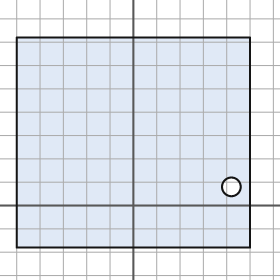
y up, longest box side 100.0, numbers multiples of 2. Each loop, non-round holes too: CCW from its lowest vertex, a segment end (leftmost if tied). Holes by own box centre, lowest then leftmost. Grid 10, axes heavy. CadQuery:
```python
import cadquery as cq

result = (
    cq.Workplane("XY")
    .moveTo(-50.0, -18.0)
    .lineTo(50.0, -18.0)
    .lineTo(50.0, 72.0)
    .lineTo(-50.0, 72.0)
    .close()
    .moveTo(42.0, 8.0)
    .circle(4.0)
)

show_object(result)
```